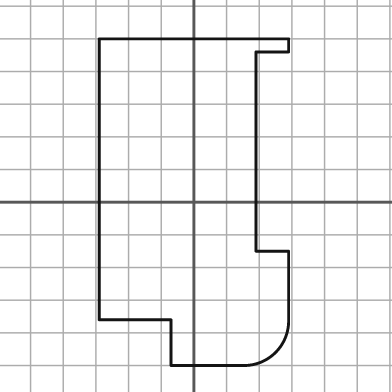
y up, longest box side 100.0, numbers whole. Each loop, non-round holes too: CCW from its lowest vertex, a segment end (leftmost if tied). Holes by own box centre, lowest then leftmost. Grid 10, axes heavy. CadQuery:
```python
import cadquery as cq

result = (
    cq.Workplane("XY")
    .moveTo(-7.0, -50.0)
    .lineTo(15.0, -50.0)
    .threePointArc((25.0, -46.0), (29.0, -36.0))
    .lineTo(29.0, -15.0)
    .lineTo(19.0, -15.0)
    .lineTo(19.0, 46.0)
    .lineTo(29.0, 46.0)
    .lineTo(29.0, 50.0)
    .lineTo(-29.0, 50.0)
    .lineTo(-29.0, -36.0)
    .lineTo(-7.0, -36.0)
    .close()
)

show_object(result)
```